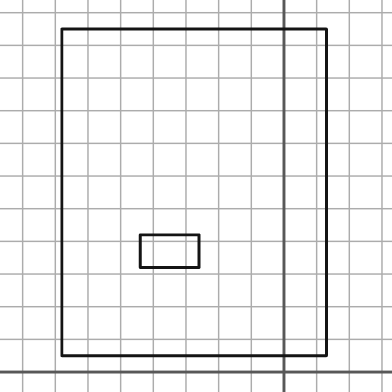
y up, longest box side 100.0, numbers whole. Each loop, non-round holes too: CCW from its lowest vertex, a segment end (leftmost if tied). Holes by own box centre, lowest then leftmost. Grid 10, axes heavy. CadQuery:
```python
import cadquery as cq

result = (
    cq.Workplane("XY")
    .moveTo(-68.0, 5.0)
    .lineTo(13.0, 5.0)
    .lineTo(13.0, 105.0)
    .lineTo(-68.0, 105.0)
    .close()
    .moveTo(-44.0, 32.0)
    .lineTo(-26.0, 32.0)
    .lineTo(-26.0, 42.0)
    .lineTo(-44.0, 42.0)
    .close()
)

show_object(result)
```